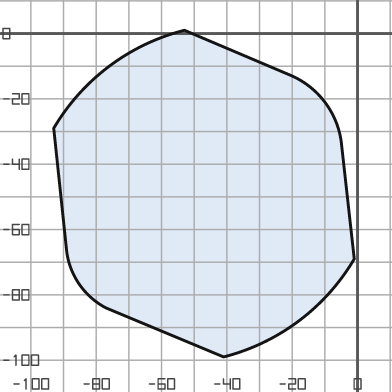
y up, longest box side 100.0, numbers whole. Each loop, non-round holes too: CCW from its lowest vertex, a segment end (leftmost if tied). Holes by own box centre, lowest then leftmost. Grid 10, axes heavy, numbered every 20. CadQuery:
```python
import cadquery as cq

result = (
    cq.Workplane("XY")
    .moveTo(-41.0, -99.0)
    .threePointArc((-18.0, -88.0), (-1.0, -69.0))
    .lineTo(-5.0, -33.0)
    .threePointArc((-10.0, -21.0), (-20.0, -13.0))
    .lineTo(-53.0, 1.0)
    .threePointArc((-76.0, -10.0), (-93.0, -29.0))
    .lineTo(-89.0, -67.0)
    .threePointArc((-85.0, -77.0), (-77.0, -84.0))
    .close()
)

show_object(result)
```